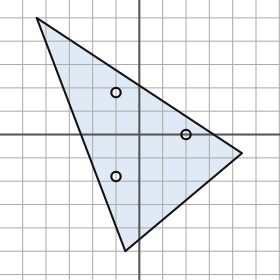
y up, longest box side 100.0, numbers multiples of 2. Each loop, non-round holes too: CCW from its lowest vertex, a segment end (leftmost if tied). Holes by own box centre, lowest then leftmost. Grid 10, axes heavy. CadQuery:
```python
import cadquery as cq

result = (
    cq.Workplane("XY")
    .moveTo(-6.0, -50.0)
    .lineTo(44.0, -8.0)
    .lineTo(-44.0, 50.0)
    .close()
    .moveTo(-10.0, -18.0)
    .circle(2.0)
    .moveTo(20.0, 0.0)
    .circle(2.0)
    .moveTo(-10.0, 18.0)
    .circle(2.0)
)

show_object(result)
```